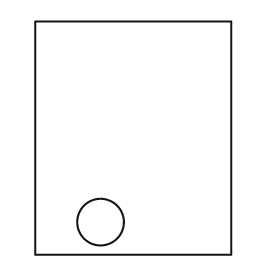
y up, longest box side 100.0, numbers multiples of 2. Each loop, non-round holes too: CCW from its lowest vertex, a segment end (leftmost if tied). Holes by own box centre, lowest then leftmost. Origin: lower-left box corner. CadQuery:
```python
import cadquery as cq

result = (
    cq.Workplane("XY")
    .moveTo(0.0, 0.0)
    .lineTo(84.0, 0.0)
    .lineTo(84.0, 100.0)
    .lineTo(0.0, 100.0)
    .close()
    .moveTo(28.0, 14.0)
    .circle(10.0)
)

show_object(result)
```